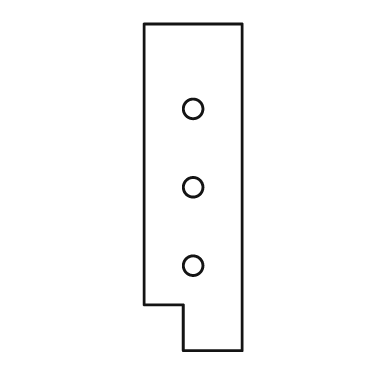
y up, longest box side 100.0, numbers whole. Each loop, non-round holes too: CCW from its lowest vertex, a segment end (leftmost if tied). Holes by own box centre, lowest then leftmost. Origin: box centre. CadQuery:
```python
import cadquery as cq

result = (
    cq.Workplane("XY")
    .moveTo(-3.0, -50.0)
    .lineTo(15.0, -50.0)
    .lineTo(15.0, 50.0)
    .lineTo(-15.0, 50.0)
    .lineTo(-15.0, -36.0)
    .lineTo(-3.0, -36.0)
    .close()
    .moveTo(0.0, -24.0)
    .circle(3.0)
    .moveTo(0.0, 0.0)
    .circle(3.0)
    .moveTo(0.0, 24.0)
    .circle(3.0)
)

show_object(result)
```